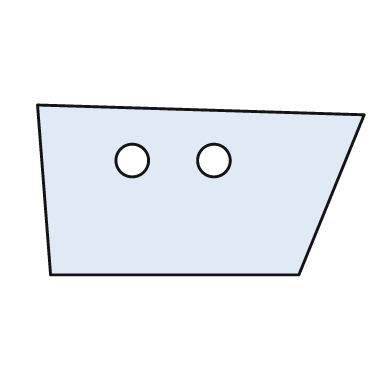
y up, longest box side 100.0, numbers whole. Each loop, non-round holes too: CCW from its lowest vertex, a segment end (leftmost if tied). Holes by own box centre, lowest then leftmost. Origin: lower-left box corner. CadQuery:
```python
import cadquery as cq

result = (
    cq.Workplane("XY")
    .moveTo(4.0, 0.0)
    .lineTo(80.0, 0.0)
    .lineTo(100.0, 49.0)
    .lineTo(0.0, 52.0)
    .close()
    .moveTo(29.0, 35.0)
    .circle(5.0)
    .moveTo(54.0, 35.0)
    .circle(5.0)
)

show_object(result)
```